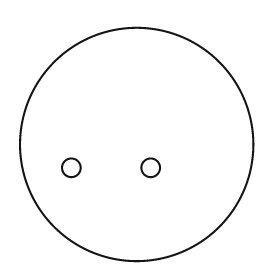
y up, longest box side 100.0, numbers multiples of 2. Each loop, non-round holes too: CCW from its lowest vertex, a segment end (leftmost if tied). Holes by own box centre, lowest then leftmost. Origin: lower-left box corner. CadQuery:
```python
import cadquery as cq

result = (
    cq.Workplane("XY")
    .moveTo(50.0, 50.0)
    .circle(50.0)
    .moveTo(22.0, 40.0)
    .circle(4.0)
    .moveTo(56.0, 40.0)
    .circle(4.0)
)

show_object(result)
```